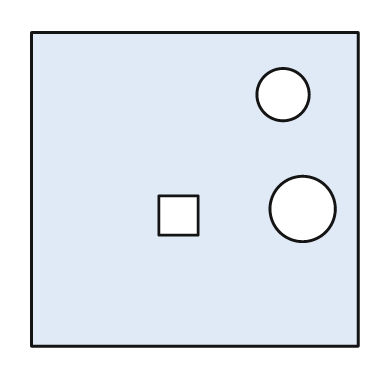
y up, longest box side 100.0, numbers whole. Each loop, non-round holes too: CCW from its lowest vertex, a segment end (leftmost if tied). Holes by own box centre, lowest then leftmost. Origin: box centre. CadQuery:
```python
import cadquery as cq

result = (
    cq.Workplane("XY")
    .moveTo(-50.0, -48.0)
    .lineTo(50.0, -48.0)
    .lineTo(50.0, 48.0)
    .lineTo(-50.0, 48.0)
    .close()
    .moveTo(-11.0, -14.0)
    .lineTo(1.0, -14.0)
    .lineTo(1.0, -2.0)
    .lineTo(-11.0, -2.0)
    .close()
    .moveTo(33.0, -6.0)
    .circle(10.0)
    .moveTo(27.0, 29.0)
    .circle(8.0)
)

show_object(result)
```